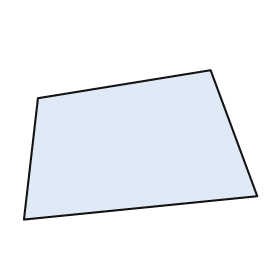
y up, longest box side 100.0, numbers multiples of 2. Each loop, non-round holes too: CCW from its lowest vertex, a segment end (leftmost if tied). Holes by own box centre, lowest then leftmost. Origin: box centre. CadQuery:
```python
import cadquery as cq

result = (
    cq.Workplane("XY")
    .moveTo(-50.0, -32.0)
    .lineTo(50.0, -22.0)
    .lineTo(30.0, 32.0)
    .lineTo(-44.0, 20.0)
    .close()
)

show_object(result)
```